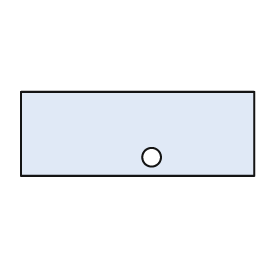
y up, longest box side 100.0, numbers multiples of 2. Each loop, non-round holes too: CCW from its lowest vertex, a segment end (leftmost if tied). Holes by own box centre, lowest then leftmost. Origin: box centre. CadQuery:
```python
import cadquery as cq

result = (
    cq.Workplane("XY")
    .moveTo(-50.0, -18.0)
    .lineTo(50.0, -18.0)
    .lineTo(50.0, 18.0)
    .lineTo(-50.0, 18.0)
    .close()
    .moveTo(6.0, -10.0)
    .circle(4.0)
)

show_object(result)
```